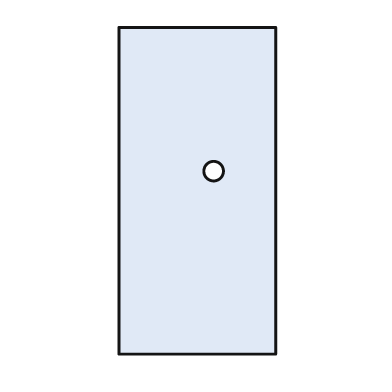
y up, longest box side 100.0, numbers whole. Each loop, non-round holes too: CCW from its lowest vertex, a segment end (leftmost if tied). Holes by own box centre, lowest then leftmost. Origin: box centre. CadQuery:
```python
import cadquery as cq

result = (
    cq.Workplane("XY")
    .moveTo(-24.0, -50.0)
    .lineTo(24.0, -50.0)
    .lineTo(24.0, 50.0)
    .lineTo(-24.0, 50.0)
    .close()
    .moveTo(5.0, 6.0)
    .circle(3.0)
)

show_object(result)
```